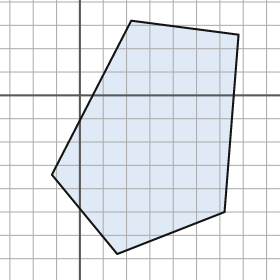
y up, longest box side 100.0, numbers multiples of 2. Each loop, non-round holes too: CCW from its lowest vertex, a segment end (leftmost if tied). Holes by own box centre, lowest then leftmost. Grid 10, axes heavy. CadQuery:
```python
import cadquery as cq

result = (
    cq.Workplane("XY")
    .moveTo(16.0, -68.0)
    .lineTo(62.0, -50.0)
    .lineTo(68.0, 26.0)
    .lineTo(22.0, 32.0)
    .lineTo(-12.0, -34.0)
    .close()
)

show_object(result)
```